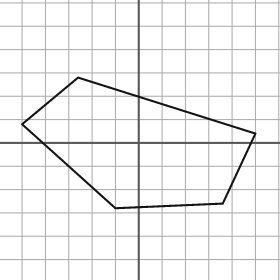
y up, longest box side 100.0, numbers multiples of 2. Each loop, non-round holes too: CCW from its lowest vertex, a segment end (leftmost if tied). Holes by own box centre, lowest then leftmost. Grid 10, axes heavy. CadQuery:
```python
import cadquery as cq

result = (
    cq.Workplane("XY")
    .moveTo(-10.0, -28.0)
    .lineTo(36.0, -26.0)
    .lineTo(50.0, 4.0)
    .lineTo(-26.0, 28.0)
    .lineTo(-50.0, 8.0)
    .close()
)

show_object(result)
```